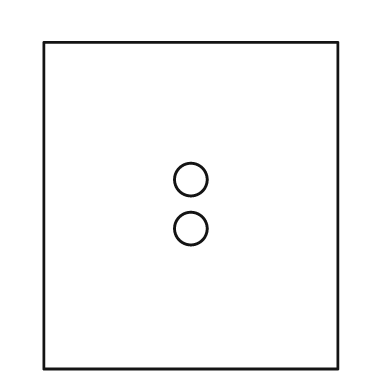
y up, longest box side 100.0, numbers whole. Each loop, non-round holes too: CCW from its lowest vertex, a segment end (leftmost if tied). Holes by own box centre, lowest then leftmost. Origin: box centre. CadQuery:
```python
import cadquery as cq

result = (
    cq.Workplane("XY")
    .moveTo(-45.0, -50.0)
    .lineTo(45.0, -50.0)
    .lineTo(45.0, 50.0)
    .lineTo(-45.0, 50.0)
    .close()
    .moveTo(0.0, -7.0)
    .circle(5.0)
    .moveTo(0.0, 8.0)
    .circle(5.0)
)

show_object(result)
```